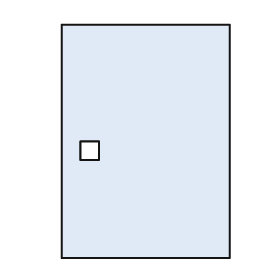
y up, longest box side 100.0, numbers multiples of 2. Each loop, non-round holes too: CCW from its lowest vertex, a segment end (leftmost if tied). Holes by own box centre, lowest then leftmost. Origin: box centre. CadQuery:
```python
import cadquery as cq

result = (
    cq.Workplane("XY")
    .moveTo(-36.0, -50.0)
    .lineTo(36.0, -50.0)
    .lineTo(36.0, 50.0)
    .lineTo(-36.0, 50.0)
    .close()
    .moveTo(-28.0, -8.0)
    .lineTo(-20.0, -8.0)
    .lineTo(-20.0, 0.0)
    .lineTo(-28.0, 0.0)
    .close()
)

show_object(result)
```